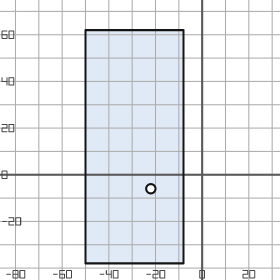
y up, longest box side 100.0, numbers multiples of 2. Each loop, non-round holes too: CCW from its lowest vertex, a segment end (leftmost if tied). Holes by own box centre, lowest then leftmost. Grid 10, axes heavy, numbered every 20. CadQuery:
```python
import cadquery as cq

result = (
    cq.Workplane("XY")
    .moveTo(-50.0, -38.0)
    .lineTo(-8.0, -38.0)
    .lineTo(-8.0, 62.0)
    .lineTo(-50.0, 62.0)
    .close()
    .moveTo(-22.0, -6.0)
    .circle(2.0)
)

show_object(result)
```